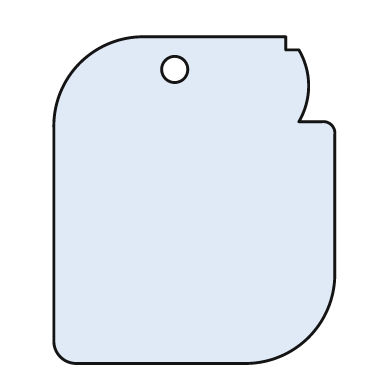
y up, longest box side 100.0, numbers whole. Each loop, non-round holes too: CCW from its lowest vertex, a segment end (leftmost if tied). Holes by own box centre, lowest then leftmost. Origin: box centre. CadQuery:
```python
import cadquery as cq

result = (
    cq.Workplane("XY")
    .moveTo(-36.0, -50.0)
    .lineTo(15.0, -50.0)
    .threePointArc((35.0, -42.0), (43.0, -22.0))
    .lineTo(43.0, 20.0)
    .threePointArc((42.0, 23.0), (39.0, 24.0))
    .lineTo(32.0, 24.0)
    .threePointArc((35.0, 35.0), (32.0, 46.0))
    .lineTo(28.0, 46.0)
    .lineTo(28.0, 50.0)
    .lineTo(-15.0, 50.0)
    .threePointArc((-35.0, 42.0), (-43.0, 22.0))
    .lineTo(-43.0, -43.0)
    .threePointArc((-41.0, -48.0), (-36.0, -50.0))
    .close()
    .moveTo(-6.0, 40.0)
    .circle(4.0)
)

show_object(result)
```